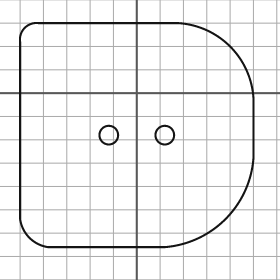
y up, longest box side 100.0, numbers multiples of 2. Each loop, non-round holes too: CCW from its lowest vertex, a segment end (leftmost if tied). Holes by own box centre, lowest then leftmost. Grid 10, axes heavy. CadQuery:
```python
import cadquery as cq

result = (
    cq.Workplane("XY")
    .moveTo(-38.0, -66.0)
    .lineTo(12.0, -66.0)
    .threePointArc((38.0, -54.0), (50.0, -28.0))
    .lineTo(50.0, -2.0)
    .threePointArc((40.0, 20.0), (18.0, 30.0))
    .lineTo(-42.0, 30.0)
    .threePointArc((-48.0, 28.0), (-50.0, 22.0))
    .lineTo(-50.0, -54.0)
    .threePointArc((-46.0, -62.0), (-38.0, -66.0))
    .close()
    .moveTo(-12.0, -18.0)
    .circle(4.0)
    .moveTo(12.0, -18.0)
    .circle(4.0)
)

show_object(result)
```